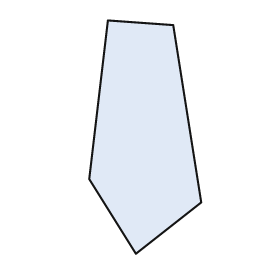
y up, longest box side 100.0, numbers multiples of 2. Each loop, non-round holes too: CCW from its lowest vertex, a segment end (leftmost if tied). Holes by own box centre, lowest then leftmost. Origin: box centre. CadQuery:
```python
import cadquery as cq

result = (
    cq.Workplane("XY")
    .moveTo(-4.0, -50.0)
    .lineTo(24.0, -28.0)
    .lineTo(12.0, 48.0)
    .lineTo(-16.0, 50.0)
    .lineTo(-24.0, -18.0)
    .close()
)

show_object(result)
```